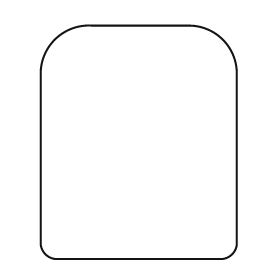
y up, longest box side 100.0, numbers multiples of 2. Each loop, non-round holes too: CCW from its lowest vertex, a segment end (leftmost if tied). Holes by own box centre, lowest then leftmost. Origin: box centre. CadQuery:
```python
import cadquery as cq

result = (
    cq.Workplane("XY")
    .moveTo(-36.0, -50.0)
    .lineTo(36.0, -50.0)
    .threePointArc((40.0, -48.0), (42.0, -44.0))
    .lineTo(42.0, 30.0)
    .threePointArc((36.0, 44.0), (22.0, 50.0))
    .lineTo(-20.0, 50.0)
    .threePointArc((-36.0, 44.0), (-42.0, 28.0))
    .lineTo(-42.0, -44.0)
    .threePointArc((-40.0, -48.0), (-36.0, -50.0))
    .close()
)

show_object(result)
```